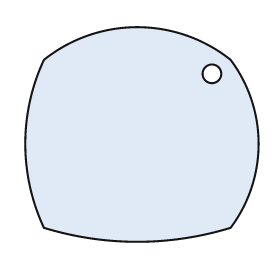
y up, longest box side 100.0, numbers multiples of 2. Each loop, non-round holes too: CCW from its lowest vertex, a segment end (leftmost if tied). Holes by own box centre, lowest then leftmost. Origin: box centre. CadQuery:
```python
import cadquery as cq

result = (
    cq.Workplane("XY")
    .moveTo(-42.0, -40.0)
    .threePointArc((-2.0, -46.0), (38.0, -40.0))
    .threePointArc((50.0, -4.0), (38.0, 32.0))
    .threePointArc((-2.0, 46.0), (-42.0, 32.0))
    .threePointArc((-50.0, -4.0), (-42.0, -40.0))
    .close()
    .moveTo(30.0, 26.0)
    .circle(4.0)
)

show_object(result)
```